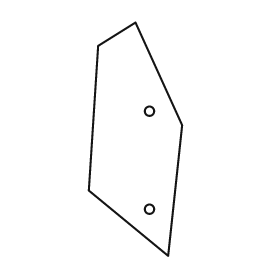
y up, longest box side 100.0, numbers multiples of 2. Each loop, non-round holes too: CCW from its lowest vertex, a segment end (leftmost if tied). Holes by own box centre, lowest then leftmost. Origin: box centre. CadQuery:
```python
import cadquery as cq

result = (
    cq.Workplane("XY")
    .moveTo(14.0, -50.0)
    .lineTo(20.0, 6.0)
    .lineTo(0.0, 50.0)
    .lineTo(-16.0, 40.0)
    .lineTo(-20.0, -22.0)
    .close()
    .moveTo(6.0, -30.0)
    .circle(2.0)
    .moveTo(6.0, 12.0)
    .circle(2.0)
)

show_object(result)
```